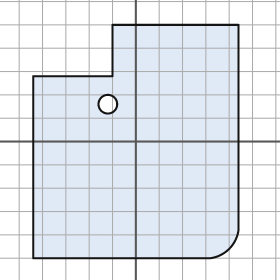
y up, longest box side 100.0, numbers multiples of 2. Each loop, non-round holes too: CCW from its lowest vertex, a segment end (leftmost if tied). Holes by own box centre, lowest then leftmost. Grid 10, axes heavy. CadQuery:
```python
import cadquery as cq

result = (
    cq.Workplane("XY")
    .moveTo(-44.0, -50.0)
    .lineTo(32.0, -50.0)
    .threePointArc((40.0, -46.0), (44.0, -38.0))
    .lineTo(44.0, 50.0)
    .lineTo(-10.0, 50.0)
    .lineTo(-10.0, 28.0)
    .lineTo(-44.0, 28.0)
    .close()
    .moveTo(-12.0, 16.0)
    .circle(4.0)
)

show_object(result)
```